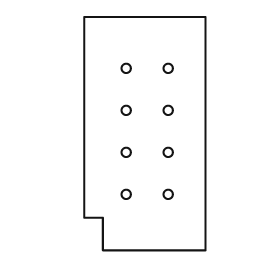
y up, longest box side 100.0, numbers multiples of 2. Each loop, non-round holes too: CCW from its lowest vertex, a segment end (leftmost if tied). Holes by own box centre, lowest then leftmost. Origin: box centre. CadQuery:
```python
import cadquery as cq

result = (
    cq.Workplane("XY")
    .moveTo(-18.0, -50.0)
    .lineTo(26.0, -50.0)
    .lineTo(26.0, 50.0)
    .lineTo(-26.0, 50.0)
    .lineTo(-26.0, -36.0)
    .lineTo(-18.0, -36.0)
    .close()
    .moveTo(-8.0, -26.0)
    .circle(2.0)
    .moveTo(10.0, -26.0)
    .circle(2.0)
    .moveTo(-8.0, -8.0)
    .circle(2.0)
    .moveTo(10.0, -8.0)
    .circle(2.0)
    .moveTo(-8.0, 10.0)
    .circle(2.0)
    .moveTo(10.0, 10.0)
    .circle(2.0)
    .moveTo(-8.0, 28.0)
    .circle(2.0)
    .moveTo(10.0, 28.0)
    .circle(2.0)
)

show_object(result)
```